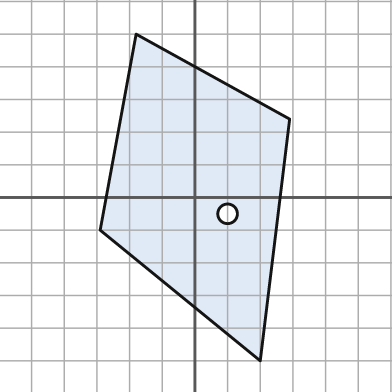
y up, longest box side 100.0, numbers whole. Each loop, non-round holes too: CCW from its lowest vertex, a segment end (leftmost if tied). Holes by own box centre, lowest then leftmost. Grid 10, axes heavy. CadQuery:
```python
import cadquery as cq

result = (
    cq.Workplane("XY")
    .moveTo(20.0, -50.0)
    .lineTo(29.0, 24.0)
    .lineTo(-18.0, 50.0)
    .lineTo(-29.0, -10.0)
    .close()
    .moveTo(10.0, -5.0)
    .circle(3.0)
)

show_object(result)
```